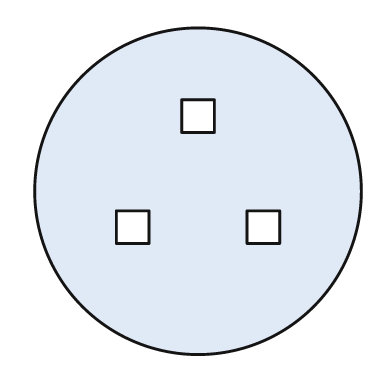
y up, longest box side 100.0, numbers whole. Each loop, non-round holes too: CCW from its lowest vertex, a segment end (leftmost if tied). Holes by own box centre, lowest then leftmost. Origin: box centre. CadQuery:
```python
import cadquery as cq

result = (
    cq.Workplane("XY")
    .moveTo(0.0, 0.0)
    .circle(50.0)
    .moveTo(-25.0, -16.0)
    .lineTo(-15.0, -16.0)
    .lineTo(-15.0, -6.0)
    .lineTo(-25.0, -6.0)
    .close()
    .moveTo(15.0, -16.0)
    .lineTo(25.0, -16.0)
    .lineTo(25.0, -6.0)
    .lineTo(15.0, -6.0)
    .close()
    .moveTo(-5.0, 18.0)
    .lineTo(5.0, 18.0)
    .lineTo(5.0, 28.0)
    .lineTo(-5.0, 28.0)
    .close()
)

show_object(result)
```